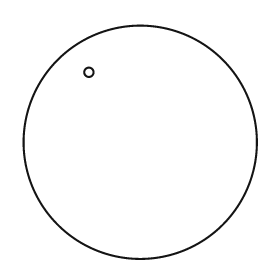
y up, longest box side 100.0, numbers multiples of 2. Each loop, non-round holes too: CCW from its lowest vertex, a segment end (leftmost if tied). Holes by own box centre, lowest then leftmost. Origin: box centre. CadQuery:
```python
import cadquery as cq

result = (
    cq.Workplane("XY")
    .moveTo(0.0, 0.0)
    .circle(50.0)
    .moveTo(-22.0, 30.0)
    .circle(2.0)
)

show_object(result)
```